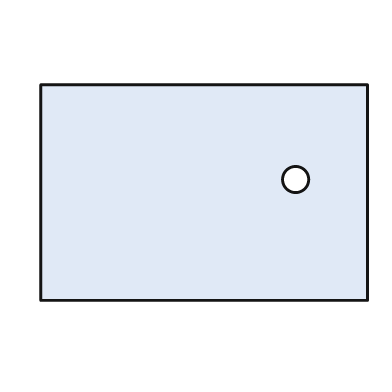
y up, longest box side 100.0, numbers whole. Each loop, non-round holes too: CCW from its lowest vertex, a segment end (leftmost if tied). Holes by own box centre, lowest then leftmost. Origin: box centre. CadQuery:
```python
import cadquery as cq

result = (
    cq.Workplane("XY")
    .moveTo(-50.0, -33.0)
    .lineTo(50.0, -33.0)
    .lineTo(50.0, 33.0)
    .lineTo(-50.0, 33.0)
    .close()
    .moveTo(28.0, 4.0)
    .circle(4.0)
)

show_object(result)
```